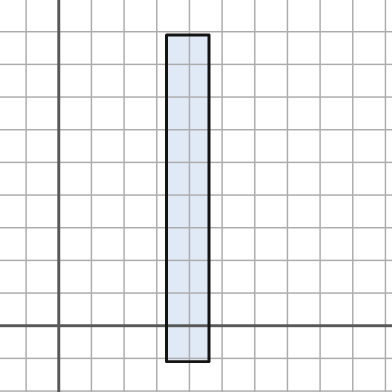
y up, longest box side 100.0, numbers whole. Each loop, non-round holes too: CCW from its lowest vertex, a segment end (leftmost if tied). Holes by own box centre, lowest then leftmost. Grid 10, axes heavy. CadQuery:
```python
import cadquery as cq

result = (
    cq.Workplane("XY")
    .moveTo(33.0, -11.0)
    .lineTo(46.0, -11.0)
    .lineTo(46.0, 89.0)
    .lineTo(33.0, 89.0)
    .close()
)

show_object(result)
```